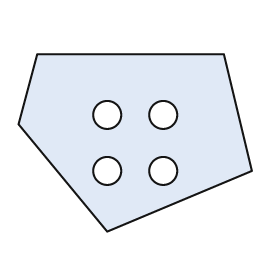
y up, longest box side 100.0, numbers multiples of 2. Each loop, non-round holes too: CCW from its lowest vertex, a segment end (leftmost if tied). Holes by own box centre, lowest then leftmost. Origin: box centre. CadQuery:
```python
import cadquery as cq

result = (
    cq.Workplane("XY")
    .moveTo(-12.0, -38.0)
    .lineTo(50.0, -12.0)
    .lineTo(38.0, 38.0)
    .lineTo(-42.0, 38.0)
    .lineTo(-50.0, 8.0)
    .close()
    .moveTo(-12.0, -12.0)
    .circle(6.0)
    .moveTo(12.0, -12.0)
    .circle(6.0)
    .moveTo(-12.0, 12.0)
    .circle(6.0)
    .moveTo(12.0, 12.0)
    .circle(6.0)
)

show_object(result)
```